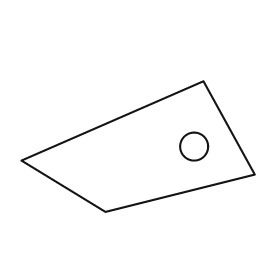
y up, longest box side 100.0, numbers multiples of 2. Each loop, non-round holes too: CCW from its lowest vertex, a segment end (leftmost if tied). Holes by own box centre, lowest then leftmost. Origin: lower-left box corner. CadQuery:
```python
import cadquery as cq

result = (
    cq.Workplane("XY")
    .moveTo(36.0, 0.0)
    .lineTo(100.0, 16.0)
    .lineTo(78.0, 56.0)
    .lineTo(0.0, 22.0)
    .close()
    .moveTo(74.0, 28.0)
    .circle(6.0)
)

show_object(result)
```